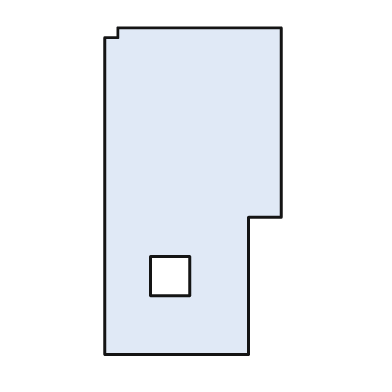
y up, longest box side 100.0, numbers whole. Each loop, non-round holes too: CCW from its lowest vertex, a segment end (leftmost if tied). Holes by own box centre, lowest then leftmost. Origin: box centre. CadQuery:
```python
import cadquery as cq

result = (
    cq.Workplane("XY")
    .moveTo(-27.0, -50.0)
    .lineTo(17.0, -50.0)
    .lineTo(17.0, -8.0)
    .lineTo(27.0, -8.0)
    .lineTo(27.0, 50.0)
    .lineTo(-23.0, 50.0)
    .lineTo(-23.0, 47.0)
    .lineTo(-27.0, 47.0)
    .close()
    .moveTo(-13.0, -32.0)
    .lineTo(-1.0, -32.0)
    .lineTo(-1.0, -20.0)
    .lineTo(-13.0, -20.0)
    .close()
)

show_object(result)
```